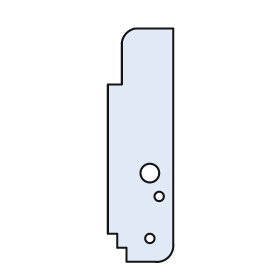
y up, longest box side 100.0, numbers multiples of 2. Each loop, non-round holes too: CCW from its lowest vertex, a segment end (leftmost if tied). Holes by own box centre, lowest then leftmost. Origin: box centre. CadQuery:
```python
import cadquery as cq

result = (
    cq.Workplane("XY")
    .moveTo(-6.0, -50.0)
    .lineTo(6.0, -50.0)
    .threePointArc((12.0, -48.0), (14.0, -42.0))
    .lineTo(14.0, 50.0)
    .lineTo(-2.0, 50.0)
    .threePointArc((-6.0, 48.0), (-8.0, 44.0))
    .lineTo(-8.0, 26.0)
    .lineTo(-14.0, 26.0)
    .lineTo(-14.0, -38.0)
    .lineTo(-10.0, -38.0)
    .lineTo(-10.0, -44.0)
    .lineTo(-6.0, -44.0)
    .close()
    .moveTo(4.0, -40.0)
    .circle(2.0)
    .moveTo(8.0, -22.0)
    .circle(2.0)
    .moveTo(4.0, -12.0)
    .circle(4.0)
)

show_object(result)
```